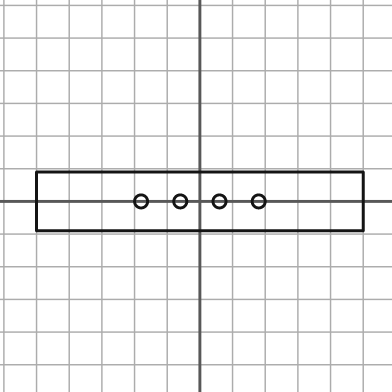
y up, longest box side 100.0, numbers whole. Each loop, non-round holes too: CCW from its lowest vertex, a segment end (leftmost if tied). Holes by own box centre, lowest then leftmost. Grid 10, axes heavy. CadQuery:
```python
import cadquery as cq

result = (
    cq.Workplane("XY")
    .moveTo(-50.0, -9.0)
    .lineTo(50.0, -9.0)
    .lineTo(50.0, 9.0)
    .lineTo(-50.0, 9.0)
    .close()
    .moveTo(-18.0, 0.0)
    .circle(2.0)
    .moveTo(-6.0, 0.0)
    .circle(2.0)
    .moveTo(6.0, 0.0)
    .circle(2.0)
    .moveTo(18.0, 0.0)
    .circle(2.0)
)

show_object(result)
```